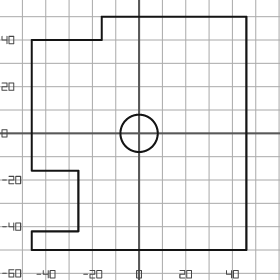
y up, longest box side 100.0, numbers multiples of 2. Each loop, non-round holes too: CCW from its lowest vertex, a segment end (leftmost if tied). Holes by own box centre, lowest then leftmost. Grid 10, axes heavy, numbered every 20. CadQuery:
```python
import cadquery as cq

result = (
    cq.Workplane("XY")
    .moveTo(-46.0, -50.0)
    .lineTo(46.0, -50.0)
    .lineTo(46.0, 50.0)
    .lineTo(-16.0, 50.0)
    .lineTo(-16.0, 40.0)
    .lineTo(-46.0, 40.0)
    .lineTo(-46.0, -16.0)
    .lineTo(-26.0, -16.0)
    .lineTo(-26.0, -42.0)
    .lineTo(-46.0, -42.0)
    .close()
    .moveTo(0.0, 0.0)
    .circle(8.0)
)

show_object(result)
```